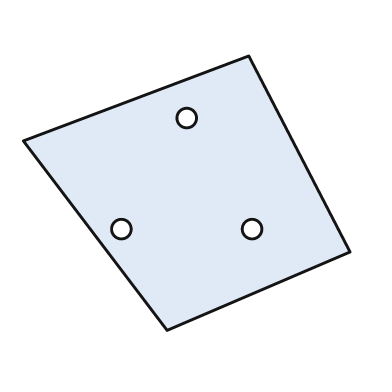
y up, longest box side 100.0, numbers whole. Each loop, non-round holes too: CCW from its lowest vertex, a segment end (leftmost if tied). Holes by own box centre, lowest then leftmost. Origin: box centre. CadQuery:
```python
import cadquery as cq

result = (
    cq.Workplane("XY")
    .moveTo(-6.0, -42.0)
    .lineTo(50.0, -18.0)
    .lineTo(19.0, 42.0)
    .lineTo(-50.0, 16.0)
    .close()
    .moveTo(-20.0, -11.0)
    .circle(3.0)
    .moveTo(20.0, -11.0)
    .circle(3.0)
    .moveTo(0.0, 23.0)
    .circle(3.0)
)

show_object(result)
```